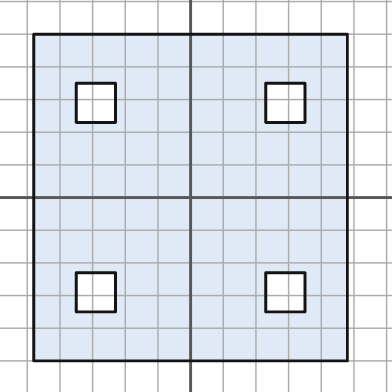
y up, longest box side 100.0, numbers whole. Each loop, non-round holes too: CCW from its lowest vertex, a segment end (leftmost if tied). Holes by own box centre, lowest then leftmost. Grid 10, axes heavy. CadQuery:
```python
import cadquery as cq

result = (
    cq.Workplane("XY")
    .moveTo(-48.0, -50.0)
    .lineTo(48.0, -50.0)
    .lineTo(48.0, 50.0)
    .lineTo(-48.0, 50.0)
    .close()
    .moveTo(-35.0, -35.0)
    .lineTo(-23.0, -35.0)
    .lineTo(-23.0, -23.0)
    .lineTo(-35.0, -23.0)
    .close()
    .moveTo(23.0, -35.0)
    .lineTo(35.0, -35.0)
    .lineTo(35.0, -23.0)
    .lineTo(23.0, -23.0)
    .close()
    .moveTo(-35.0, 23.0)
    .lineTo(-23.0, 23.0)
    .lineTo(-23.0, 35.0)
    .lineTo(-35.0, 35.0)
    .close()
    .moveTo(23.0, 23.0)
    .lineTo(35.0, 23.0)
    .lineTo(35.0, 35.0)
    .lineTo(23.0, 35.0)
    .close()
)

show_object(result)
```